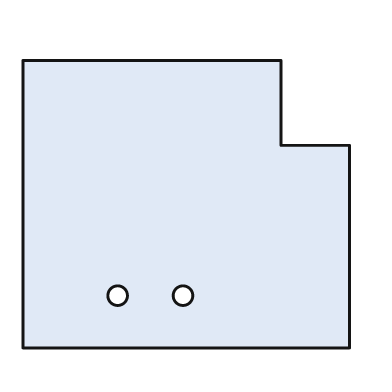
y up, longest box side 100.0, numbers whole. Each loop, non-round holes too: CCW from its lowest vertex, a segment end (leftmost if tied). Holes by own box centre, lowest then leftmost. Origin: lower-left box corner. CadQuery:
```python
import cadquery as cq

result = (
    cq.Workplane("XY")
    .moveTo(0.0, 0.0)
    .lineTo(100.0, 0.0)
    .lineTo(100.0, 62.0)
    .lineTo(79.0, 62.0)
    .lineTo(79.0, 88.0)
    .lineTo(0.0, 88.0)
    .close()
    .moveTo(29.0, 16.0)
    .circle(3.0)
    .moveTo(49.0, 16.0)
    .circle(3.0)
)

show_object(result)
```